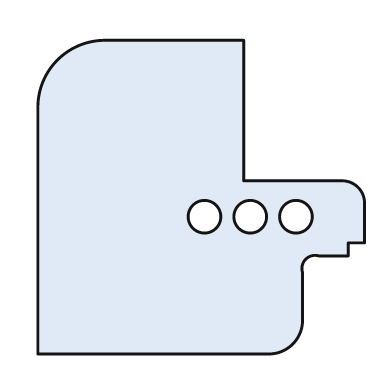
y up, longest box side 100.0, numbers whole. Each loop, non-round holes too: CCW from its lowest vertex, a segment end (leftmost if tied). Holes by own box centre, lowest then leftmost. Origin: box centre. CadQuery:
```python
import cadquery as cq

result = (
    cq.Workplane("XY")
    .moveTo(-50.0, -48.0)
    .lineTo(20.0, -48.0)
    .threePointArc((28.0, -45.0), (31.0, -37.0))
    .lineTo(31.0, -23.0)
    .threePointArc((32.0, -19.0), (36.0, -18.0))
    .lineTo(45.0, -18.0)
    .lineTo(45.0, -14.0)
    .lineTo(50.0, -14.0)
    .lineTo(50.0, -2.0)
    .threePointArc((48.0, 3.0), (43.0, 5.0))
    .lineTo(13.0, 5.0)
    .lineTo(13.0, 48.0)
    .lineTo(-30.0, 48.0)
    .threePointArc((-44.0, 42.0), (-50.0, 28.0))
    .close()
    .moveTo(1.0, -6.0)
    .circle(5.0)
    .moveTo(15.0, -6.0)
    .circle(5.0)
    .moveTo(29.0, -6.0)
    .circle(5.0)
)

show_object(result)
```